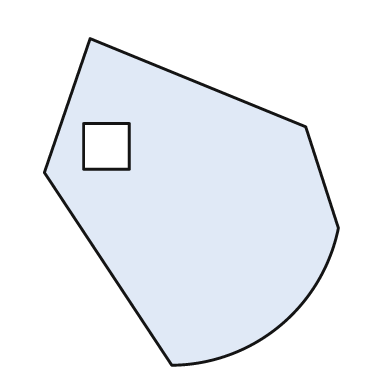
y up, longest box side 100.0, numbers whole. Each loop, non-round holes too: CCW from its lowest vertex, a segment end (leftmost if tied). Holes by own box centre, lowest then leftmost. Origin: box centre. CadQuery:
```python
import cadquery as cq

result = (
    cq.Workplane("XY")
    .moveTo(-6.0, -50.0)
    .threePointArc((27.0, -38.0), (45.0, -8.0))
    .lineTo(35.0, 23.0)
    .lineTo(-31.0, 50.0)
    .lineTo(-45.0, 9.0)
    .close()
    .moveTo(-33.0, 10.0)
    .lineTo(-19.0, 10.0)
    .lineTo(-19.0, 24.0)
    .lineTo(-33.0, 24.0)
    .close()
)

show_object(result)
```